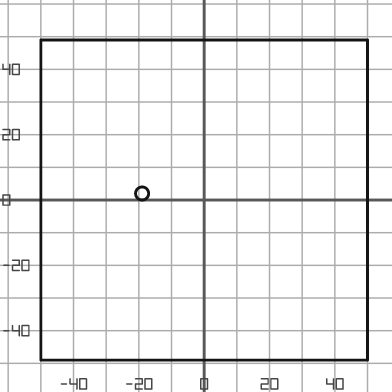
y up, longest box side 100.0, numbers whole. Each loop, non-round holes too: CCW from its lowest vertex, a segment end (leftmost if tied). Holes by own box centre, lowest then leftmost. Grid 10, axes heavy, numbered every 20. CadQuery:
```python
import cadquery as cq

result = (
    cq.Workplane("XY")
    .moveTo(-50.0, -49.0)
    .lineTo(50.0, -49.0)
    .lineTo(50.0, 49.0)
    .lineTo(-50.0, 49.0)
    .close()
    .moveTo(-19.0, 2.0)
    .circle(2.0)
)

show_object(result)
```